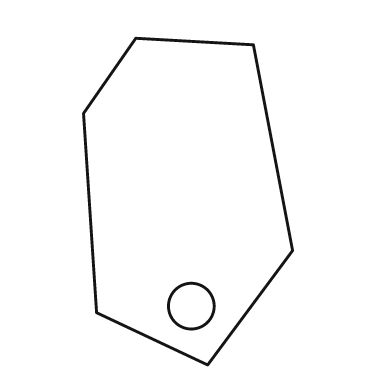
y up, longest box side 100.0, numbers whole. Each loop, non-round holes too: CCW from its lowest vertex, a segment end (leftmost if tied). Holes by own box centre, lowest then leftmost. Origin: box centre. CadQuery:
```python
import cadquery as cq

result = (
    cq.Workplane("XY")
    .moveTo(6.0, -50.0)
    .lineTo(32.0, -15.0)
    .lineTo(20.0, 48.0)
    .lineTo(-16.0, 50.0)
    .lineTo(-32.0, 27.0)
    .lineTo(-28.0, -34.0)
    .close()
    .moveTo(1.0, -32.0)
    .circle(7.0)
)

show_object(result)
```